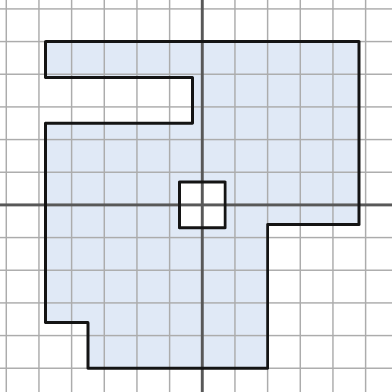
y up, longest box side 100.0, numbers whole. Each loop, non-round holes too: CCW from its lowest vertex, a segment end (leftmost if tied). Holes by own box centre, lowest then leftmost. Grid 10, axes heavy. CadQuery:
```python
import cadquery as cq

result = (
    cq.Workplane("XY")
    .moveTo(-35.0, -50.0)
    .lineTo(20.0, -50.0)
    .lineTo(20.0, -6.0)
    .lineTo(48.0, -6.0)
    .lineTo(48.0, 50.0)
    .lineTo(-48.0, 50.0)
    .lineTo(-48.0, 39.0)
    .lineTo(-3.0, 39.0)
    .lineTo(-3.0, 25.0)
    .lineTo(-48.0, 25.0)
    .lineTo(-48.0, -36.0)
    .lineTo(-35.0, -36.0)
    .close()
    .moveTo(-7.0, -7.0)
    .lineTo(7.0, -7.0)
    .lineTo(7.0, 7.0)
    .lineTo(-7.0, 7.0)
    .close()
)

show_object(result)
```